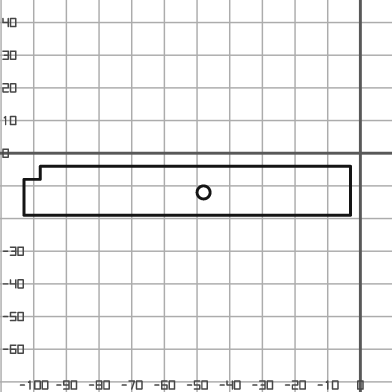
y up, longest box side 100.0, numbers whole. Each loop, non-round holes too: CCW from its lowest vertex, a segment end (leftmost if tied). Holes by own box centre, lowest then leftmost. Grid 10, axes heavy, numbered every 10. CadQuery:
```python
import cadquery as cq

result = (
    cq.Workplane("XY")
    .moveTo(-103.0, -19.0)
    .lineTo(-3.0, -19.0)
    .lineTo(-3.0, -4.0)
    .lineTo(-98.0, -4.0)
    .lineTo(-98.0, -8.0)
    .lineTo(-103.0, -8.0)
    .close()
    .moveTo(-48.0, -12.0)
    .circle(2.0)
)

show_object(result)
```